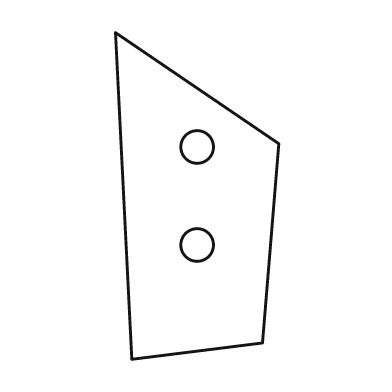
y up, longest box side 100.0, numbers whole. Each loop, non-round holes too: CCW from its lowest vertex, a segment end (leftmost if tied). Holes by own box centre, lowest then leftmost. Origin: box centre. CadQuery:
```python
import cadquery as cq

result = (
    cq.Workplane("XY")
    .moveTo(-20.0, -50.0)
    .lineTo(20.0, -45.0)
    .lineTo(25.0, 16.0)
    .lineTo(-25.0, 50.0)
    .close()
    .moveTo(0.0, -15.0)
    .circle(5.0)
    .moveTo(0.0, 15.0)
    .circle(5.0)
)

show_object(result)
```